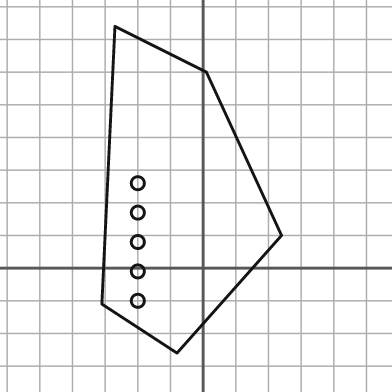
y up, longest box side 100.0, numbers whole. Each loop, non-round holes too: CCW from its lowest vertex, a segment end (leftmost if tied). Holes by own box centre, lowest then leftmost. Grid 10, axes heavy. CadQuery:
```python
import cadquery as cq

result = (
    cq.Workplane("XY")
    .moveTo(-8.0, -26.0)
    .lineTo(24.0, 10.0)
    .lineTo(1.0, 60.0)
    .lineTo(-27.0, 74.0)
    .lineTo(-31.0, -11.0)
    .close()
    .moveTo(-20.0, -10.0)
    .circle(2.0)
    .moveTo(-20.0, -1.0)
    .circle(2.0)
    .moveTo(-20.0, 8.0)
    .circle(2.0)
    .moveTo(-20.0, 17.0)
    .circle(2.0)
    .moveTo(-20.0, 26.0)
    .circle(2.0)
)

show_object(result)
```